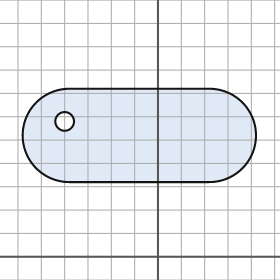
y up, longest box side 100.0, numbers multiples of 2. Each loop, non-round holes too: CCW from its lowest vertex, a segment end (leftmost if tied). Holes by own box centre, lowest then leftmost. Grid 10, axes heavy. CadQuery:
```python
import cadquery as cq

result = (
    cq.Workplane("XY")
    .moveTo(-38.0, 32.0)
    .lineTo(22.0, 32.0)
    .threePointArc((42.0, 52.0), (22.0, 72.0))
    .lineTo(-38.0, 72.0)
    .threePointArc((-58.0, 52.0), (-38.0, 32.0))
    .close()
    .moveTo(-40.0, 58.0)
    .circle(4.0)
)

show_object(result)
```